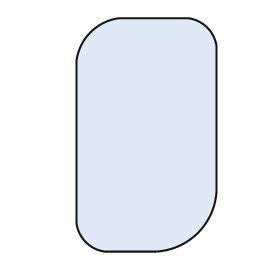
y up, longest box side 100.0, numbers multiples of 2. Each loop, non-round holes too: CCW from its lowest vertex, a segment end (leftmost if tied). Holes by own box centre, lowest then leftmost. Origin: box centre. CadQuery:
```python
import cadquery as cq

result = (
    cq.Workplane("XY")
    .moveTo(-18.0, -50.0)
    .lineTo(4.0, -50.0)
    .threePointArc((22.0, -42.0), (30.0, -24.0))
    .lineTo(30.0, 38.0)
    .threePointArc((26.0, 46.0), (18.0, 50.0))
    .lineTo(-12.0, 50.0)
    .threePointArc((-24.0, 44.0), (-30.0, 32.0))
    .lineTo(-30.0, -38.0)
    .threePointArc((-26.0, -46.0), (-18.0, -50.0))
    .close()
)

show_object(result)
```